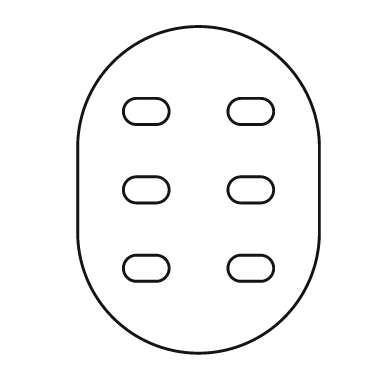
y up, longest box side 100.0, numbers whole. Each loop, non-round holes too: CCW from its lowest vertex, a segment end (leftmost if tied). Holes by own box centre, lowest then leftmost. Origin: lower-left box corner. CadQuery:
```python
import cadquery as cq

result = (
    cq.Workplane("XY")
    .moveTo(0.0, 37.0)
    .threePointArc((37.0, 0.0), (74.0, 37.0))
    .lineTo(74.0, 63.0)
    .threePointArc((37.0, 100.0), (0.0, 63.0))
    .close()
    .moveTo(18.0, 22.0)
    .lineTo(24.0, 22.0)
    .threePointArc((28.0, 26.0), (24.0, 30.0))
    .lineTo(18.0, 30.0)
    .threePointArc((14.0, 26.0), (18.0, 22.0))
    .close()
    .moveTo(50.0, 22.0)
    .lineTo(56.0, 22.0)
    .threePointArc((60.0, 26.0), (56.0, 30.0))
    .lineTo(50.0, 30.0)
    .threePointArc((46.0, 26.0), (50.0, 22.0))
    .close()
    .moveTo(18.0, 46.0)
    .lineTo(24.0, 46.0)
    .threePointArc((28.0, 50.0), (24.0, 54.0))
    .lineTo(18.0, 54.0)
    .threePointArc((14.0, 50.0), (18.0, 46.0))
    .close()
    .moveTo(50.0, 46.0)
    .lineTo(56.0, 46.0)
    .threePointArc((60.0, 50.0), (56.0, 54.0))
    .lineTo(50.0, 54.0)
    .threePointArc((46.0, 50.0), (50.0, 46.0))
    .close()
    .moveTo(18.0, 70.0)
    .lineTo(24.0, 70.0)
    .threePointArc((28.0, 74.0), (24.0, 78.0))
    .lineTo(18.0, 78.0)
    .threePointArc((14.0, 74.0), (18.0, 70.0))
    .close()
    .moveTo(50.0, 70.0)
    .lineTo(56.0, 70.0)
    .threePointArc((60.0, 74.0), (56.0, 78.0))
    .lineTo(50.0, 78.0)
    .threePointArc((46.0, 74.0), (50.0, 70.0))
    .close()
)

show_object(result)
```